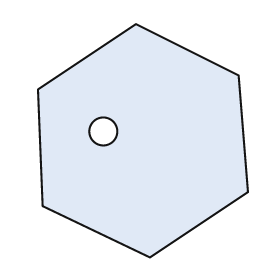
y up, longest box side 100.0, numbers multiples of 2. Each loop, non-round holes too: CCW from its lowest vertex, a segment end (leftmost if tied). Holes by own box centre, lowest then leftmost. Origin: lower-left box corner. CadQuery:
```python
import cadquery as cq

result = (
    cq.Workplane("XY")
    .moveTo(48.0, 0.0)
    .lineTo(90.0, 28.0)
    .lineTo(86.0, 78.0)
    .lineTo(42.0, 100.0)
    .lineTo(0.0, 72.0)
    .lineTo(2.0, 22.0)
    .close()
    .moveTo(28.0, 54.0)
    .circle(6.0)
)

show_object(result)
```